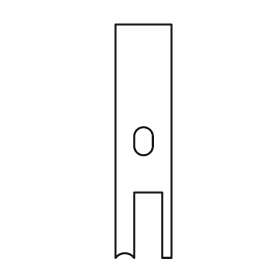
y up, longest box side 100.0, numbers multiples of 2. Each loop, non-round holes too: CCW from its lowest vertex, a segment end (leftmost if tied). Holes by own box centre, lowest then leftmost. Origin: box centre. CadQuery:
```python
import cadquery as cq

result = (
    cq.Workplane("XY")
    .moveTo(-12.0, -50.0)
    .threePointArc((-8.0, -48.0), (-4.0, -50.0))
    .lineTo(-4.0, -22.0)
    .lineTo(8.0, -22.0)
    .lineTo(8.0, -50.0)
    .lineTo(12.0, -50.0)
    .lineTo(12.0, 50.0)
    .lineTo(-12.0, 50.0)
    .close()
    .moveTo(-4.0, -2.0)
    .threePointArc((0.0, -6.0), (4.0, -2.0))
    .lineTo(4.0, 2.0)
    .threePointArc((0.0, 6.0), (-4.0, 2.0))
    .close()
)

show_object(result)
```